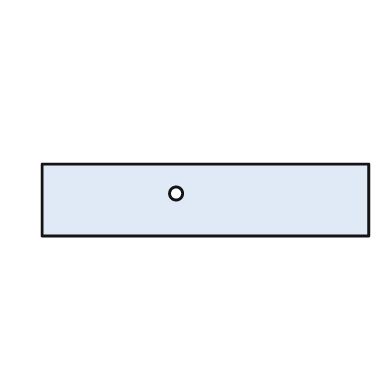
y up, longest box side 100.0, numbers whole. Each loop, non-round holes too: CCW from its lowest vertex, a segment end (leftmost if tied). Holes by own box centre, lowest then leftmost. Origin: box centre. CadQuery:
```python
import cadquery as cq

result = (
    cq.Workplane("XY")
    .moveTo(-50.0, -11.0)
    .lineTo(50.0, -11.0)
    .lineTo(50.0, 11.0)
    .lineTo(-50.0, 11.0)
    .close()
    .moveTo(-9.0, 2.0)
    .circle(2.0)
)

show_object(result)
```